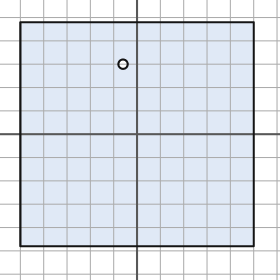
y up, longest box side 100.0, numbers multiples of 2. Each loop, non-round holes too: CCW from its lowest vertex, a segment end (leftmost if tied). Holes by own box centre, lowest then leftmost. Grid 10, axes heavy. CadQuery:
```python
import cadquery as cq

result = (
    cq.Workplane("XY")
    .moveTo(-50.0, -48.0)
    .lineTo(50.0, -48.0)
    .lineTo(50.0, 48.0)
    .lineTo(-50.0, 48.0)
    .close()
    .moveTo(-6.0, 30.0)
    .circle(2.0)
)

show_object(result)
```